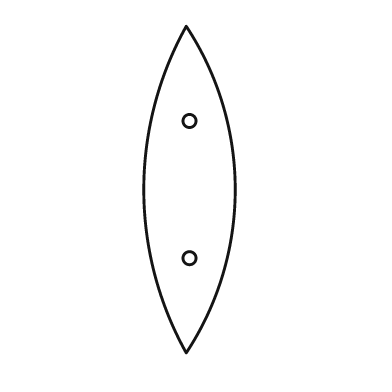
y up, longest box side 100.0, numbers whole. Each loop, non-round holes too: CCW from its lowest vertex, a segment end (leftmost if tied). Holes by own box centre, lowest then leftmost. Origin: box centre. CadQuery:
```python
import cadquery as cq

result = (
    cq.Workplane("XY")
    .moveTo(-1.0, -50.0)
    .threePointArc((14.0, 0.0), (-1.0, 50.0))
    .threePointArc((-14.0, 0.0), (-1.0, -50.0))
    .close()
    .moveTo(0.0, -21.0)
    .circle(2.0)
    .moveTo(0.0, 21.0)
    .circle(2.0)
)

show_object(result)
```